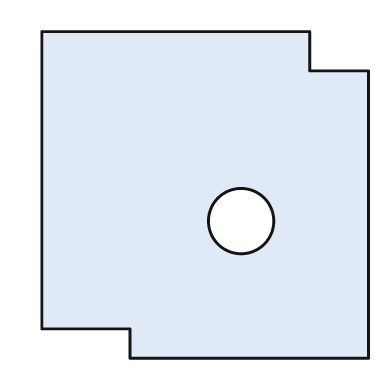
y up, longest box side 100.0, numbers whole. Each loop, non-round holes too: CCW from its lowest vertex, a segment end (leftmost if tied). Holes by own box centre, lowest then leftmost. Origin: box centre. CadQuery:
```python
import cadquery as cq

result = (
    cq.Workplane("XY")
    .moveTo(-23.0, -50.0)
    .lineTo(50.0, -50.0)
    .lineTo(50.0, 38.0)
    .lineTo(32.0, 38.0)
    .lineTo(32.0, 50.0)
    .lineTo(-50.0, 50.0)
    .lineTo(-50.0, -41.0)
    .lineTo(-23.0, -41.0)
    .close()
    .moveTo(11.0, -8.0)
    .circle(10.0)
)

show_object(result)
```